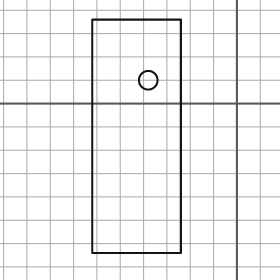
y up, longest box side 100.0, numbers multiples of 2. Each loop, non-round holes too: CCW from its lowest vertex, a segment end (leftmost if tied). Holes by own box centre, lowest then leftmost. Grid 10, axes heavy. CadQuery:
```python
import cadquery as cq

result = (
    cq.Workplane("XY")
    .moveTo(-62.0, -64.0)
    .lineTo(-24.0, -64.0)
    .lineTo(-24.0, 36.0)
    .lineTo(-62.0, 36.0)
    .close()
    .moveTo(-38.0, 10.0)
    .circle(4.0)
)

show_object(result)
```